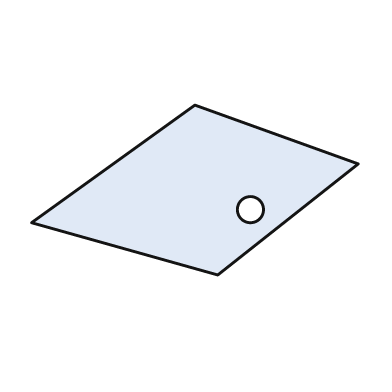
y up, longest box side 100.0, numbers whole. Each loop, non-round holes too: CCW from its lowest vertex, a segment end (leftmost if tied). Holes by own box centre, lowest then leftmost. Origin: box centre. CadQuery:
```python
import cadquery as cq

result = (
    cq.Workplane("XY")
    .moveTo(7.0, -26.0)
    .lineTo(50.0, 8.0)
    .lineTo(0.0, 26.0)
    .lineTo(-50.0, -10.0)
    .close()
    .moveTo(17.0, -6.0)
    .circle(4.0)
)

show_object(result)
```